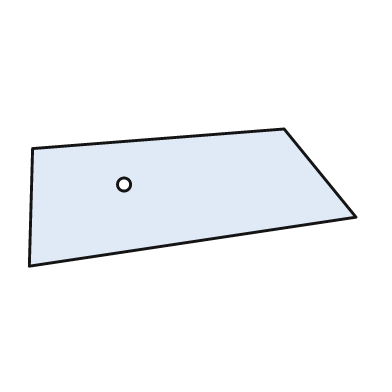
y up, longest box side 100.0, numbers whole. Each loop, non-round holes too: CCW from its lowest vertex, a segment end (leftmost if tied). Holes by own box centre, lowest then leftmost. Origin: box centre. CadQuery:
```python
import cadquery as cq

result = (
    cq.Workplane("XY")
    .moveTo(-50.0, -21.0)
    .lineTo(50.0, -6.0)
    .lineTo(28.0, 21.0)
    .lineTo(-49.0, 15.0)
    .close()
    .moveTo(-21.0, 4.0)
    .circle(2.0)
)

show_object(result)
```